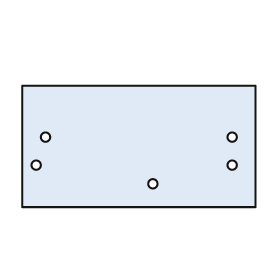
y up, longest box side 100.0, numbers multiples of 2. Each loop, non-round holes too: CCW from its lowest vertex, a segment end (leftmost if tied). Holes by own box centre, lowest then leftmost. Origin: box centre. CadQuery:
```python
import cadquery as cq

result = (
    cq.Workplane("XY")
    .moveTo(-50.0, -26.0)
    .lineTo(50.0, -26.0)
    .lineTo(50.0, 26.0)
    .lineTo(-50.0, 26.0)
    .close()
    .moveTo(6.0, -16.0)
    .circle(2.0)
    .moveTo(-44.0, -8.0)
    .circle(2.0)
    .moveTo(40.0, -8.0)
    .circle(2.0)
    .moveTo(-40.0, 4.0)
    .circle(2.0)
    .moveTo(40.0, 4.0)
    .circle(2.0)
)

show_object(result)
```